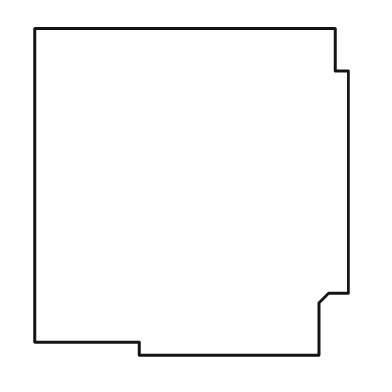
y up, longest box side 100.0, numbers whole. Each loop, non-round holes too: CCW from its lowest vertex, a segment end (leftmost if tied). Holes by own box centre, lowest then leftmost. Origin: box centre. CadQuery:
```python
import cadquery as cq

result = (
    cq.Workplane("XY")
    .moveTo(-16.0, -50.0)
    .lineTo(39.0, -50.0)
    .lineTo(39.0, -34.0)
    .lineTo(42.0, -31.0)
    .lineTo(48.0, -31.0)
    .lineTo(48.0, 37.0)
    .lineTo(44.0, 37.0)
    .lineTo(44.0, 50.0)
    .lineTo(-48.0, 50.0)
    .lineTo(-48.0, -46.0)
    .lineTo(-16.0, -46.0)
    .close()
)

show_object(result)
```